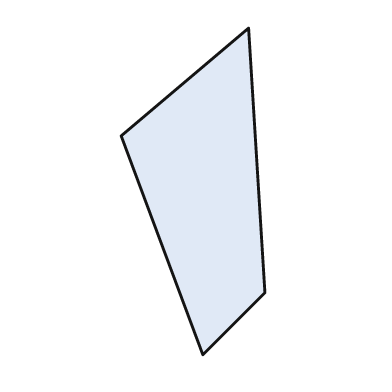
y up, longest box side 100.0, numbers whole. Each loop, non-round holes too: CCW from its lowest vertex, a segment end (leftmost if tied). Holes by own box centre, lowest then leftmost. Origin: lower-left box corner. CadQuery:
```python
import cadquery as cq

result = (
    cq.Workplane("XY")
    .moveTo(25.0, 0.0)
    .lineTo(44.0, 19.0)
    .lineTo(39.0, 100.0)
    .lineTo(0.0, 67.0)
    .close()
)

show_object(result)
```